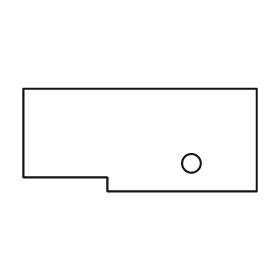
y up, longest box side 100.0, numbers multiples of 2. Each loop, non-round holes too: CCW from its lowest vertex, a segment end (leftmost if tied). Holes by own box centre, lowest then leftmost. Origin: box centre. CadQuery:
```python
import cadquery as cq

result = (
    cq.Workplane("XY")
    .moveTo(-14.0, -22.0)
    .lineTo(50.0, -22.0)
    .lineTo(50.0, 22.0)
    .lineTo(-50.0, 22.0)
    .lineTo(-50.0, -16.0)
    .lineTo(-14.0, -16.0)
    .close()
    .moveTo(22.0, -10.0)
    .circle(4.0)
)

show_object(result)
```